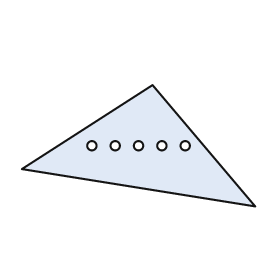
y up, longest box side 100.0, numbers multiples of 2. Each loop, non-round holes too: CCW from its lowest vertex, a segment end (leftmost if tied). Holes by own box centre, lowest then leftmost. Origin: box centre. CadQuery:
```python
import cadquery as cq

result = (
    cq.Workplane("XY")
    .moveTo(50.0, -26.0)
    .lineTo(6.0, 26.0)
    .lineTo(-50.0, -10.0)
    .close()
    .moveTo(-20.0, 0.0)
    .circle(2.0)
    .moveTo(-10.0, 0.0)
    .circle(2.0)
    .moveTo(0.0, 0.0)
    .circle(2.0)
    .moveTo(10.0, 0.0)
    .circle(2.0)
    .moveTo(20.0, 0.0)
    .circle(2.0)
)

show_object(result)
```